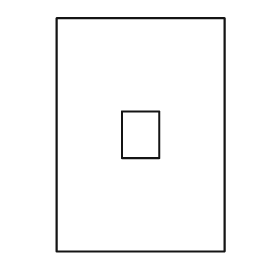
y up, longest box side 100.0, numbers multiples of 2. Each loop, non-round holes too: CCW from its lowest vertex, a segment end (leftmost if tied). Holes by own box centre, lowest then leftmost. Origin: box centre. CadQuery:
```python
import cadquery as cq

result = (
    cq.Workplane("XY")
    .moveTo(-36.0, -50.0)
    .lineTo(36.0, -50.0)
    .lineTo(36.0, 50.0)
    .lineTo(-36.0, 50.0)
    .close()
    .moveTo(-8.0, -10.0)
    .lineTo(8.0, -10.0)
    .lineTo(8.0, 10.0)
    .lineTo(-8.0, 10.0)
    .close()
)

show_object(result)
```